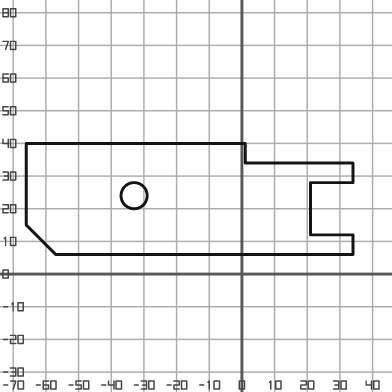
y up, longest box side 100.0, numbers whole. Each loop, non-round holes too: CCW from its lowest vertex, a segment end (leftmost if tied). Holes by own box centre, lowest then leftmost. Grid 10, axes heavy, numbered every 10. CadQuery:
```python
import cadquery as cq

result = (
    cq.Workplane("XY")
    .moveTo(-57.0, 6.0)
    .lineTo(34.0, 6.0)
    .lineTo(34.0, 12.0)
    .lineTo(21.0, 12.0)
    .lineTo(21.0, 28.0)
    .lineTo(34.0, 28.0)
    .lineTo(34.0, 34.0)
    .lineTo(1.0, 34.0)
    .lineTo(1.0, 40.0)
    .lineTo(-66.0, 40.0)
    .lineTo(-66.0, 15.0)
    .close()
    .moveTo(-33.0, 24.0)
    .circle(4.0)
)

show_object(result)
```